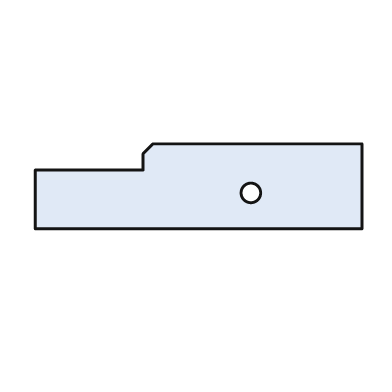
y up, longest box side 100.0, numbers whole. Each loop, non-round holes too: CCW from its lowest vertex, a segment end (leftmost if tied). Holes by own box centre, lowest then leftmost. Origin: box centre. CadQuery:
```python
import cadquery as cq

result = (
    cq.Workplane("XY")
    .moveTo(-50.0, -13.0)
    .lineTo(50.0, -13.0)
    .lineTo(50.0, 13.0)
    .lineTo(-14.0, 13.0)
    .lineTo(-17.0, 10.0)
    .lineTo(-17.0, 5.0)
    .lineTo(-50.0, 5.0)
    .close()
    .moveTo(16.0, -2.0)
    .circle(3.0)
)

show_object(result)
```